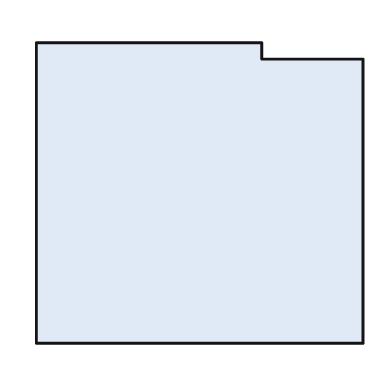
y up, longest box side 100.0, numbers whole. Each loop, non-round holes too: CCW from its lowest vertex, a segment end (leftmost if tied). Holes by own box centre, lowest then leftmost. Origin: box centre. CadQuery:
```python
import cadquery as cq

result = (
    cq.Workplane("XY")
    .moveTo(-50.0, -46.0)
    .lineTo(50.0, -46.0)
    .lineTo(50.0, 41.0)
    .lineTo(19.0, 41.0)
    .lineTo(19.0, 46.0)
    .lineTo(-50.0, 46.0)
    .close()
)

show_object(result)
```